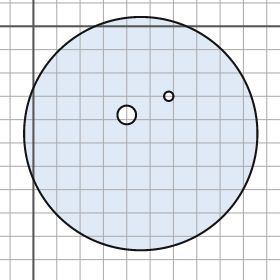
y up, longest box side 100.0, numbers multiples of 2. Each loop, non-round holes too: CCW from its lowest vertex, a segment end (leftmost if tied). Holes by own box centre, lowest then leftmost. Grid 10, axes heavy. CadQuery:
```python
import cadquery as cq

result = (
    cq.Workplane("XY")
    .moveTo(46.0, -46.0)
    .circle(50.0)
    .moveTo(40.0, -38.0)
    .circle(4.0)
    .moveTo(58.0, -30.0)
    .circle(2.0)
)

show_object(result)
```